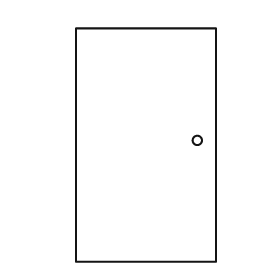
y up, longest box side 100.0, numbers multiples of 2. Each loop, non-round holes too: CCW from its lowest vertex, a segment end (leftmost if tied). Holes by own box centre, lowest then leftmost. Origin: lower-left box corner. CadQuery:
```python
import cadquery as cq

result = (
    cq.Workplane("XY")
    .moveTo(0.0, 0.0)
    .lineTo(60.0, 0.0)
    .lineTo(60.0, 100.0)
    .lineTo(0.0, 100.0)
    .close()
    .moveTo(52.0, 52.0)
    .circle(2.0)
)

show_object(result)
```